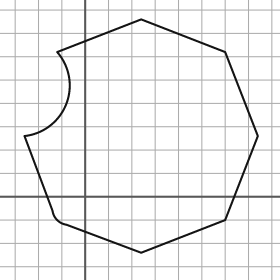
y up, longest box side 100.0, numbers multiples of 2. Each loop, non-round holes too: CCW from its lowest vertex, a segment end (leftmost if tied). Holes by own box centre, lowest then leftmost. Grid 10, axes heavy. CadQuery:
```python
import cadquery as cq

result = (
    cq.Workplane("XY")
    .moveTo(24.0, -24.0)
    .lineTo(60.0, -10.0)
    .lineTo(74.0, 26.0)
    .lineTo(60.0, 62.0)
    .lineTo(24.0, 76.0)
    .lineTo(-12.0, 62.0)
    .threePointArc((-8.0, 40.0), (-26.0, 26.0))
    .lineTo(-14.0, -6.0)
    .threePointArc((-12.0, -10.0), (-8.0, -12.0))
    .close()
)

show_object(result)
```